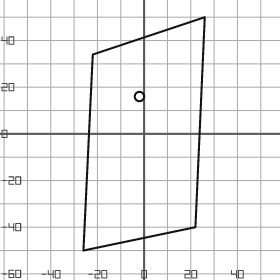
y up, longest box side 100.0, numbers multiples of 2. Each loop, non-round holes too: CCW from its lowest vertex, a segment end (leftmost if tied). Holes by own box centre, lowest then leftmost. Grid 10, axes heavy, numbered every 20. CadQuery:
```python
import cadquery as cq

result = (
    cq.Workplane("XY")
    .moveTo(-26.0, -50.0)
    .lineTo(22.0, -40.0)
    .lineTo(26.0, 50.0)
    .lineTo(-22.0, 34.0)
    .close()
    .moveTo(-2.0, 16.0)
    .circle(2.0)
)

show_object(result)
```